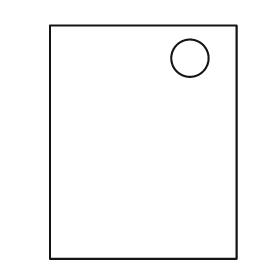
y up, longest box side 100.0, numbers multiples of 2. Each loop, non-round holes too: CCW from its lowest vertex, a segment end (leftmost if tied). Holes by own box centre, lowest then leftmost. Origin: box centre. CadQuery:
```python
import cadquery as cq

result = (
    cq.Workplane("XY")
    .moveTo(-40.0, -50.0)
    .lineTo(40.0, -50.0)
    .lineTo(40.0, 50.0)
    .lineTo(-40.0, 50.0)
    .close()
    .moveTo(20.0, 36.0)
    .circle(8.0)
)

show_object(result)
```